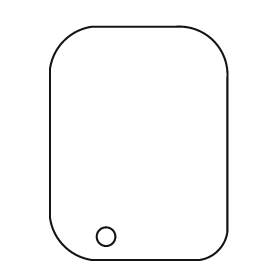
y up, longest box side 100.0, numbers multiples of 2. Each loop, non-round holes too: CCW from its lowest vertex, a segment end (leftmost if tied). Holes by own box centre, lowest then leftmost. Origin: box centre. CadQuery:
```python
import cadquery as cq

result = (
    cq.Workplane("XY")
    .moveTo(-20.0, -50.0)
    .lineTo(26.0, -50.0)
    .threePointArc((34.0, -46.0), (38.0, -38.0))
    .lineTo(38.0, 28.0)
    .threePointArc((32.0, 44.0), (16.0, 50.0))
    .lineTo(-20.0, 50.0)
    .threePointArc((-32.0, 44.0), (-38.0, 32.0))
    .lineTo(-38.0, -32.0)
    .threePointArc((-32.0, -44.0), (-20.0, -50.0))
    .close()
    .moveTo(-14.0, -40.0)
    .circle(4.0)
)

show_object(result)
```